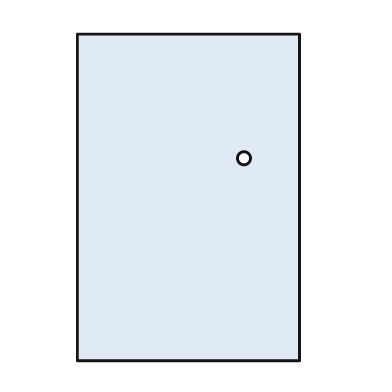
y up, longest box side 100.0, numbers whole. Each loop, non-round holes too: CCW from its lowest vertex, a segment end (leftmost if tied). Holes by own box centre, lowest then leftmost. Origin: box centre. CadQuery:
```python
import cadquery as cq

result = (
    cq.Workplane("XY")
    .moveTo(-34.0, -50.0)
    .lineTo(34.0, -50.0)
    .lineTo(34.0, 50.0)
    .lineTo(-34.0, 50.0)
    .close()
    .moveTo(17.0, 12.0)
    .circle(2.0)
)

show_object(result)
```